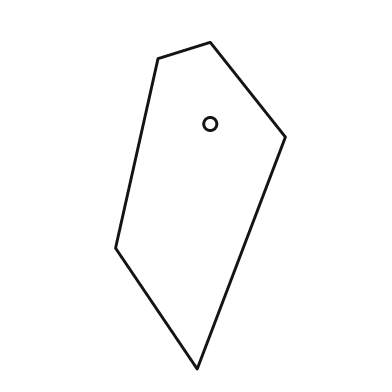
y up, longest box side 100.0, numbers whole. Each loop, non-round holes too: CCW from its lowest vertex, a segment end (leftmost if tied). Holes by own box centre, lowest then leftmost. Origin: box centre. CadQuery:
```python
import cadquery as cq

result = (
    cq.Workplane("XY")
    .moveTo(-1.0, -50.0)
    .lineTo(26.0, 21.0)
    .lineTo(3.0, 50.0)
    .lineTo(-13.0, 45.0)
    .lineTo(-26.0, -13.0)
    .close()
    .moveTo(3.0, 25.0)
    .circle(2.0)
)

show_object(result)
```